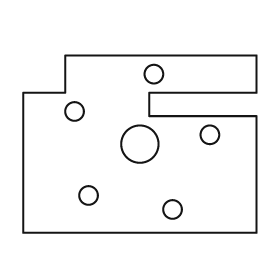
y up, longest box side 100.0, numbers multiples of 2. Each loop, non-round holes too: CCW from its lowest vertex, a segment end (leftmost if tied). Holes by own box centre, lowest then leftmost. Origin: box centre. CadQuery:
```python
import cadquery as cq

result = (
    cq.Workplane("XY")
    .moveTo(-50.0, -38.0)
    .lineTo(50.0, -38.0)
    .lineTo(50.0, 12.0)
    .lineTo(4.0, 12.0)
    .lineTo(4.0, 22.0)
    .lineTo(50.0, 22.0)
    .lineTo(50.0, 38.0)
    .lineTo(-32.0, 38.0)
    .lineTo(-32.0, 22.0)
    .lineTo(-50.0, 22.0)
    .close()
    .moveTo(14.0, -28.0)
    .circle(4.0)
    .moveTo(-22.0, -22.0)
    .circle(4.0)
    .moveTo(0.0, 0.0)
    .circle(8.0)
    .moveTo(30.0, 4.0)
    .circle(4.0)
    .moveTo(-28.0, 14.0)
    .circle(4.0)
    .moveTo(6.0, 30.0)
    .circle(4.0)
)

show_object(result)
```